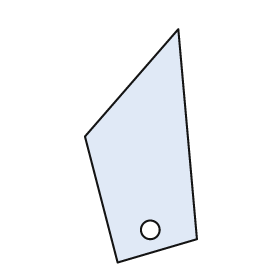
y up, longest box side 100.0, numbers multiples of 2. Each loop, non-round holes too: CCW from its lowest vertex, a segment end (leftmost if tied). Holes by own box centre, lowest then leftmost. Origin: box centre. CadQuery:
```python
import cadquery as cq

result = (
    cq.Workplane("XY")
    .moveTo(-10.0, -50.0)
    .lineTo(24.0, -40.0)
    .lineTo(16.0, 50.0)
    .lineTo(-24.0, 4.0)
    .close()
    .moveTo(4.0, -36.0)
    .circle(4.0)
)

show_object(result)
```